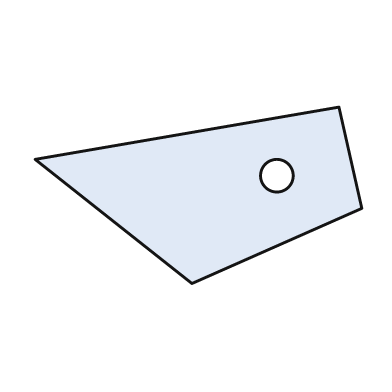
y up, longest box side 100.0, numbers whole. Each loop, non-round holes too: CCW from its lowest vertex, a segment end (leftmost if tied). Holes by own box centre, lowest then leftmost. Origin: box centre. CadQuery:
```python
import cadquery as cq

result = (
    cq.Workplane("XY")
    .moveTo(-2.0, -27.0)
    .lineTo(50.0, -4.0)
    .lineTo(43.0, 27.0)
    .lineTo(-50.0, 11.0)
    .close()
    .moveTo(24.0, 6.0)
    .circle(5.0)
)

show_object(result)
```